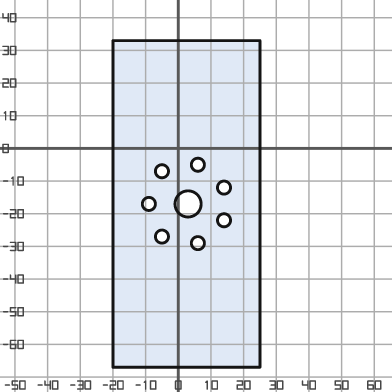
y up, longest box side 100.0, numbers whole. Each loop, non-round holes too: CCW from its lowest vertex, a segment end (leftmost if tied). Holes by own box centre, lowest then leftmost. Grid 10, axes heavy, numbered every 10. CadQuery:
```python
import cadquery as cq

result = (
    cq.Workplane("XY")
    .moveTo(-20.0, -67.0)
    .lineTo(25.0, -67.0)
    .lineTo(25.0, 33.0)
    .lineTo(-20.0, 33.0)
    .close()
    .moveTo(6.0, -29.0)
    .circle(2.0)
    .moveTo(-5.0, -27.0)
    .circle(2.0)
    .moveTo(14.0, -22.0)
    .circle(2.0)
    .moveTo(-9.0, -17.0)
    .circle(2.0)
    .moveTo(3.0, -17.0)
    .circle(4.0)
    .moveTo(14.0, -12.0)
    .circle(2.0)
    .moveTo(-5.0, -7.0)
    .circle(2.0)
    .moveTo(6.0, -5.0)
    .circle(2.0)
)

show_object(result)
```